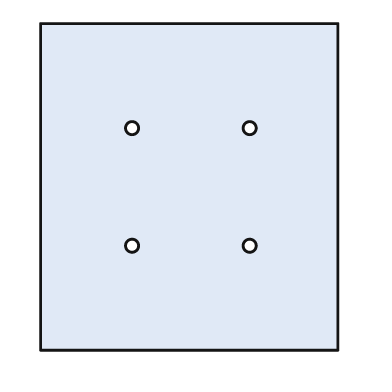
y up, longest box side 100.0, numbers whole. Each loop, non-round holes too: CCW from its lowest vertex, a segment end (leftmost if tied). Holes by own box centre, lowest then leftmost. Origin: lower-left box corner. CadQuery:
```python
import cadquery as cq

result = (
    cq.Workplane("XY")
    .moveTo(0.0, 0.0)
    .lineTo(91.0, 0.0)
    .lineTo(91.0, 100.0)
    .lineTo(0.0, 100.0)
    .close()
    .moveTo(28.0, 32.0)
    .circle(2.0)
    .moveTo(64.0, 32.0)
    .circle(2.0)
    .moveTo(28.0, 68.0)
    .circle(2.0)
    .moveTo(64.0, 68.0)
    .circle(2.0)
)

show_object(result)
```